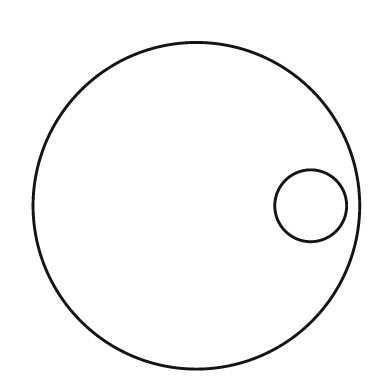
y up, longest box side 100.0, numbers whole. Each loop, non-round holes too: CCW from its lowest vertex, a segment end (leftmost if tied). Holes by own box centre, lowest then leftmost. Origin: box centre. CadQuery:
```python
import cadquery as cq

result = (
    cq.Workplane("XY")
    .moveTo(0.0, 0.0)
    .circle(50.0)
    .moveTo(35.0, 0.0)
    .circle(11.0)
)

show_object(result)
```